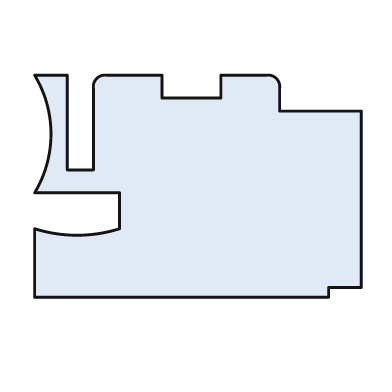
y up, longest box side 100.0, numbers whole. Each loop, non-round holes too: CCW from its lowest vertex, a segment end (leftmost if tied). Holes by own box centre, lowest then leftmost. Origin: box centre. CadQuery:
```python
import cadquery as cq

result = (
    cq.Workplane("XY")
    .moveTo(-50.0, -34.0)
    .lineTo(40.0, -34.0)
    .lineTo(40.0, -31.0)
    .lineTo(50.0, -31.0)
    .lineTo(50.0, 23.0)
    .lineTo(25.0, 23.0)
    .lineTo(25.0, 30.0)
    .threePointArc((24.0, 33.0), (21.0, 34.0))
    .lineTo(7.0, 34.0)
    .lineTo(7.0, 27.0)
    .lineTo(-11.0, 27.0)
    .lineTo(-11.0, 34.0)
    .lineTo(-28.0, 34.0)
    .threePointArc((-31.0, 33.0), (-32.0, 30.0))
    .lineTo(-32.0, 5.0)
    .lineTo(-40.0, 5.0)
    .lineTo(-40.0, 34.0)
    .lineTo(-50.0, 34.0)
    .threePointArc((-45.0, 16.0), (-50.0, -2.0))
    .lineTo(-24.0, -2.0)
    .lineTo(-24.0, -13.0)
    .threePointArc((-37.0, -15.0), (-50.0, -13.0))
    .close()
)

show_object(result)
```